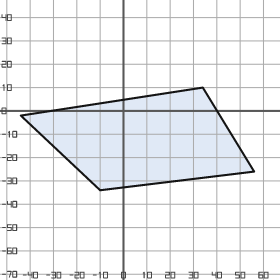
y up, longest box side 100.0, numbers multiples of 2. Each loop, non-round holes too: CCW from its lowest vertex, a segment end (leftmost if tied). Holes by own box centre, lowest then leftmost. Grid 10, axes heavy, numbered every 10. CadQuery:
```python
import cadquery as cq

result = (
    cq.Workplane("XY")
    .moveTo(-10.0, -34.0)
    .lineTo(56.0, -26.0)
    .lineTo(34.0, 10.0)
    .lineTo(-44.0, -2.0)
    .close()
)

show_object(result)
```